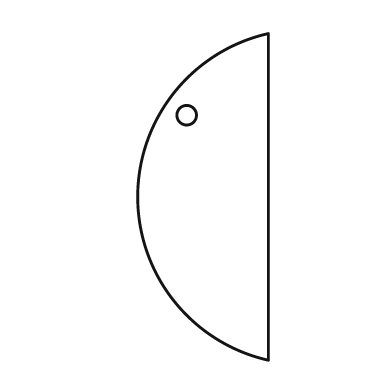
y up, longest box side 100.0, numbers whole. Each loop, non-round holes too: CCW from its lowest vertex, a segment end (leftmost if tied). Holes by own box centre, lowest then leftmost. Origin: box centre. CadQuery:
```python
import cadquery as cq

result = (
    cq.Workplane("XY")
    .moveTo(20.0, -50.0)
    .lineTo(20.0, 50.0)
    .threePointArc((-20.0, 0.0), (20.0, -50.0))
    .close()
    .moveTo(-5.0, 25.0)
    .circle(3.0)
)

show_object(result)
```